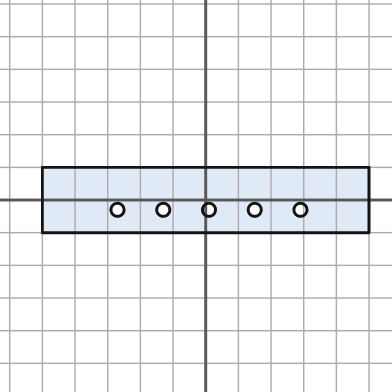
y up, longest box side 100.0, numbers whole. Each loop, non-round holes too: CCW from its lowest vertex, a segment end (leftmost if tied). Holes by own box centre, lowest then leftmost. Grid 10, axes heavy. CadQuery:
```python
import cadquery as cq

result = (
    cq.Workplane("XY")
    .moveTo(-50.0, -10.0)
    .lineTo(50.0, -10.0)
    .lineTo(50.0, 10.0)
    .lineTo(-50.0, 10.0)
    .close()
    .moveTo(-27.0, -3.0)
    .circle(2.0)
    .moveTo(-13.0, -3.0)
    .circle(2.0)
    .moveTo(1.0, -3.0)
    .circle(2.0)
    .moveTo(15.0, -3.0)
    .circle(2.0)
    .moveTo(29.0, -3.0)
    .circle(2.0)
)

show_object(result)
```